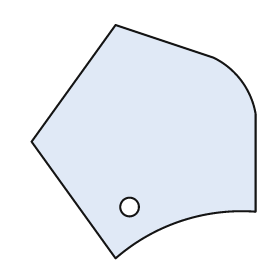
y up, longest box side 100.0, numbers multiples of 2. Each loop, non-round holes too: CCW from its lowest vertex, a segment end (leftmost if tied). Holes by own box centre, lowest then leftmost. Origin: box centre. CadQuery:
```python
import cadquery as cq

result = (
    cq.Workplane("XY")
    .moveTo(-12.0, -50.0)
    .threePointArc((16.0, -34.0), (48.0, -30.0))
    .lineTo(48.0, 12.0)
    .threePointArc((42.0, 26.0), (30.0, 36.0))
    .lineTo(-12.0, 50.0)
    .lineTo(-48.0, 0.0)
    .close()
    .moveTo(-6.0, -28.0)
    .circle(4.0)
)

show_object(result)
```